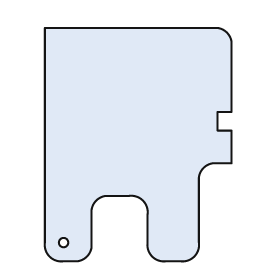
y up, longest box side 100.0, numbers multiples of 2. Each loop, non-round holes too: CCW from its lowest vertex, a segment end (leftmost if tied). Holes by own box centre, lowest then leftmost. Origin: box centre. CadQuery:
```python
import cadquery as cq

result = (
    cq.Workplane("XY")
    .moveTo(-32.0, -50.0)
    .lineTo(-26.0, -50.0)
    .threePointArc((-22.0, -48.0), (-20.0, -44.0))
    .lineTo(-20.0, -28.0)
    .threePointArc((-18.0, -24.0), (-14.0, -22.0))
    .lineTo(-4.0, -22.0)
    .threePointArc((2.0, -24.0), (4.0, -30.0))
    .lineTo(4.0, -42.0)
    .threePointArc((6.0, -48.0), (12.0, -50.0))
    .lineTo(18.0, -50.0)
    .threePointArc((24.0, -48.0), (26.0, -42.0))
    .lineTo(26.0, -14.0)
    .threePointArc((28.0, -10.0), (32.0, -8.0))
    .lineTo(40.0, -8.0)
    .lineTo(40.0, 6.0)
    .lineTo(34.0, 6.0)
    .lineTo(34.0, 14.0)
    .lineTo(40.0, 14.0)
    .lineTo(40.0, 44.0)
    .threePointArc((38.0, 48.0), (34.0, 50.0))
    .lineTo(-40.0, 50.0)
    .lineTo(-40.0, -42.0)
    .threePointArc((-38.0, -48.0), (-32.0, -50.0))
    .close()
    .moveTo(-32.0, -42.0)
    .circle(2.0)
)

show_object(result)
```